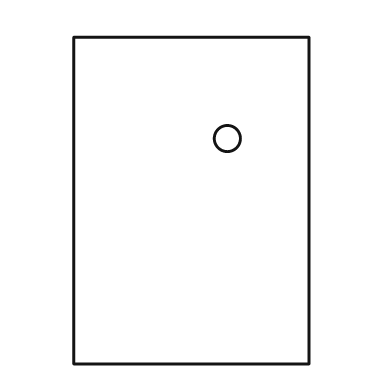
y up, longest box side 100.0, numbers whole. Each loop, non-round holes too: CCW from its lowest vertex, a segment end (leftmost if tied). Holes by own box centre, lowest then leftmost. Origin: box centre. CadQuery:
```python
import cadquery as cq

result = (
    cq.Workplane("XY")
    .moveTo(-36.0, -50.0)
    .lineTo(36.0, -50.0)
    .lineTo(36.0, 50.0)
    .lineTo(-36.0, 50.0)
    .close()
    .moveTo(11.0, 19.0)
    .circle(4.0)
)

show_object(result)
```